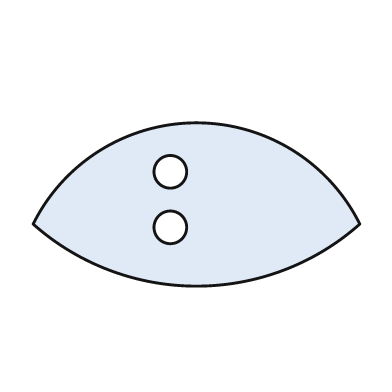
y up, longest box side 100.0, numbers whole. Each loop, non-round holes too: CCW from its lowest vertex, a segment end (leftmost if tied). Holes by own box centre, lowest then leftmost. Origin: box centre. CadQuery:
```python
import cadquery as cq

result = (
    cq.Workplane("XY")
    .moveTo(-50.0, -6.0)
    .threePointArc((0.0, -25.0), (50.0, -6.0))
    .threePointArc((0.0, 25.0), (-50.0, -6.0))
    .close()
    .moveTo(-8.0, -7.0)
    .circle(5.0)
    .moveTo(-8.0, 10.0)
    .circle(5.0)
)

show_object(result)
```